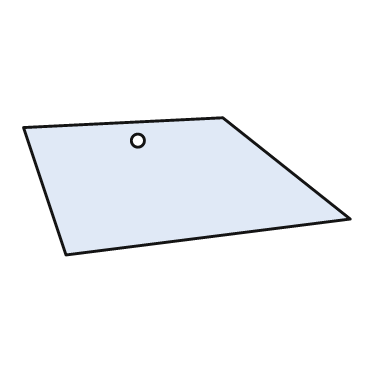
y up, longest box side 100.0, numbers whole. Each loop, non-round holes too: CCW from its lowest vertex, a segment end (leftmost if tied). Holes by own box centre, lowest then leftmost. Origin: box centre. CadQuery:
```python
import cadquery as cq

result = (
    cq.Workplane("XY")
    .moveTo(-37.0, -21.0)
    .lineTo(50.0, -10.0)
    .lineTo(11.0, 21.0)
    .lineTo(-50.0, 18.0)
    .close()
    .moveTo(-15.0, 14.0)
    .circle(2.0)
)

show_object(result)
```